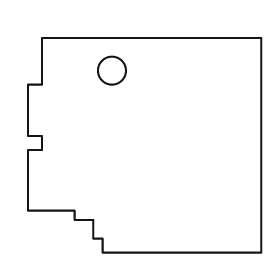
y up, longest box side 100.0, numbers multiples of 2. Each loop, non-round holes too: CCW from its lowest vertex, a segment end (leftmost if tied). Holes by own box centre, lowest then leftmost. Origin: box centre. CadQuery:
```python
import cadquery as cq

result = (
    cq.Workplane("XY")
    .moveTo(-18.0, -46.0)
    .lineTo(50.0, -46.0)
    .lineTo(50.0, 46.0)
    .lineTo(-44.0, 46.0)
    .lineTo(-44.0, 26.0)
    .lineTo(-50.0, 26.0)
    .lineTo(-50.0, 4.0)
    .lineTo(-44.0, 4.0)
    .lineTo(-44.0, -2.0)
    .lineTo(-50.0, -2.0)
    .lineTo(-50.0, -28.0)
    .lineTo(-30.0, -28.0)
    .lineTo(-30.0, -32.0)
    .lineTo(-22.0, -32.0)
    .lineTo(-22.0, -40.0)
    .lineTo(-18.0, -40.0)
    .close()
    .moveTo(-14.0, 32.0)
    .circle(6.0)
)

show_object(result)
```